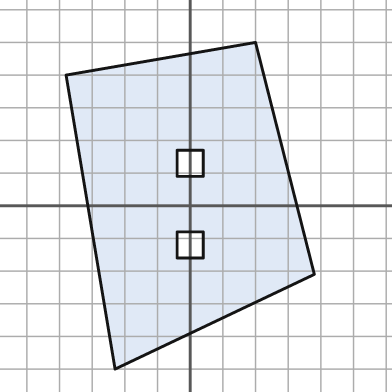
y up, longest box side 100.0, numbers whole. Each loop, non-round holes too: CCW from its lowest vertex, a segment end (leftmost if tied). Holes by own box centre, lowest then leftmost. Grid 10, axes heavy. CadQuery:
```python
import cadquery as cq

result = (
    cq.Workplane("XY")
    .moveTo(-23.0, -50.0)
    .lineTo(38.0, -21.0)
    .lineTo(20.0, 50.0)
    .lineTo(-38.0, 40.0)
    .close()
    .moveTo(-4.0, -16.0)
    .lineTo(4.0, -16.0)
    .lineTo(4.0, -8.0)
    .lineTo(-4.0, -8.0)
    .close()
    .moveTo(-4.0, 9.0)
    .lineTo(4.0, 9.0)
    .lineTo(4.0, 17.0)
    .lineTo(-4.0, 17.0)
    .close()
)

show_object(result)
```